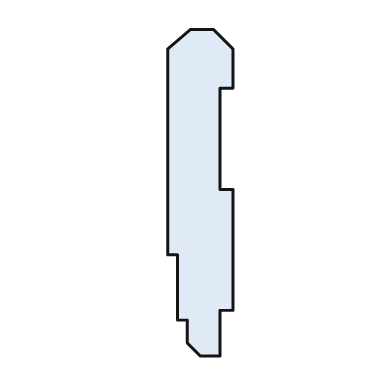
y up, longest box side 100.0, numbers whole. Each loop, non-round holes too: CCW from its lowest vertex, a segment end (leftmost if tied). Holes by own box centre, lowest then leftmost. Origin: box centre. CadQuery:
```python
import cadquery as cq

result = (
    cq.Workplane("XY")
    .moveTo(0.0, -50.0)
    .lineTo(6.0, -50.0)
    .lineTo(6.0, -36.0)
    .lineTo(10.0, -36.0)
    .lineTo(10.0, 1.0)
    .lineTo(6.0, 1.0)
    .lineTo(6.0, 32.0)
    .lineTo(10.0, 32.0)
    .lineTo(10.0, 44.0)
    .lineTo(4.0, 50.0)
    .lineTo(-3.0, 50.0)
    .lineTo(-10.0, 44.0)
    .lineTo(-10.0, -19.0)
    .lineTo(-7.0, -19.0)
    .lineTo(-7.0, -39.0)
    .lineTo(-4.0, -39.0)
    .lineTo(-4.0, -46.0)
    .close()
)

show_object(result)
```